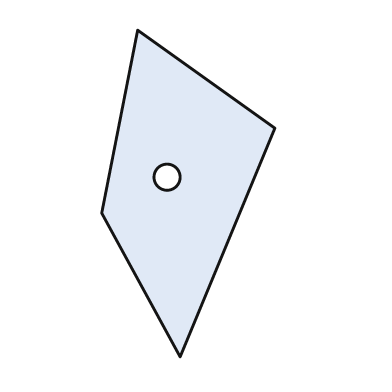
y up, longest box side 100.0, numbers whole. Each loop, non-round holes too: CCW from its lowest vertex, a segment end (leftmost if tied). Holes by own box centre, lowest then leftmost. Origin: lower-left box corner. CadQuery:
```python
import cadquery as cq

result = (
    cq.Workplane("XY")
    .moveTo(24.0, 0.0)
    .lineTo(53.0, 70.0)
    .lineTo(11.0, 100.0)
    .lineTo(0.0, 44.0)
    .close()
    .moveTo(20.0, 55.0)
    .circle(4.0)
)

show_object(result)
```